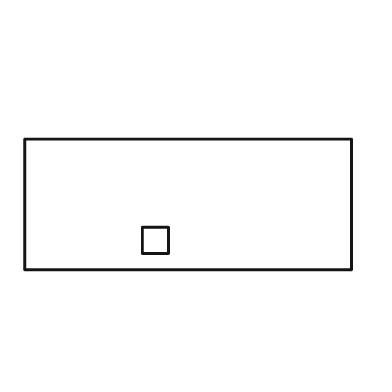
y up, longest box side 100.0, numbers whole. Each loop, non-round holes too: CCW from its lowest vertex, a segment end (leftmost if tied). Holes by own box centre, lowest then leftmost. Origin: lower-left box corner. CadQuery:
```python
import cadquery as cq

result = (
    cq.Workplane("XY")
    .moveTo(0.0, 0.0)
    .lineTo(100.0, 0.0)
    .lineTo(100.0, 40.0)
    .lineTo(0.0, 40.0)
    .close()
    .moveTo(36.0, 5.0)
    .lineTo(44.0, 5.0)
    .lineTo(44.0, 13.0)
    .lineTo(36.0, 13.0)
    .close()
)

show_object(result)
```